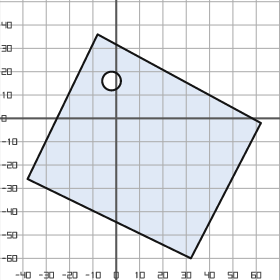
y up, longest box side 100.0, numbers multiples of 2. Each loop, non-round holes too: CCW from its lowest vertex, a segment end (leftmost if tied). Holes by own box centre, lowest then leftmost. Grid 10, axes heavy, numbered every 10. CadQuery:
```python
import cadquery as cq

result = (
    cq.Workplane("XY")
    .moveTo(32.0, -60.0)
    .lineTo(62.0, -2.0)
    .lineTo(-8.0, 36.0)
    .lineTo(-38.0, -26.0)
    .close()
    .moveTo(-2.0, 16.0)
    .circle(4.0)
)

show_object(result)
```